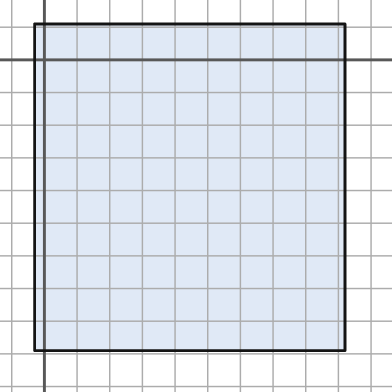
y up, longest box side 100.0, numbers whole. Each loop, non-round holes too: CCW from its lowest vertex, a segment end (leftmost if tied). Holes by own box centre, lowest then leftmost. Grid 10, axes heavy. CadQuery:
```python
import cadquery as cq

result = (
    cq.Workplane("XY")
    .moveTo(-3.0, -89.0)
    .lineTo(92.0, -89.0)
    .lineTo(92.0, 11.0)
    .lineTo(-3.0, 11.0)
    .close()
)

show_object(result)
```